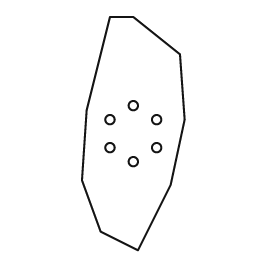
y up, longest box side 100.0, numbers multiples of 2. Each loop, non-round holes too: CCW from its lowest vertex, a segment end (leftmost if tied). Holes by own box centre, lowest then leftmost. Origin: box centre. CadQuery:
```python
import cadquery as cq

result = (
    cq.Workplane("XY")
    .moveTo(2.0, -50.0)
    .lineTo(16.0, -22.0)
    .lineTo(22.0, 6.0)
    .lineTo(20.0, 34.0)
    .lineTo(0.0, 50.0)
    .lineTo(-10.0, 50.0)
    .lineTo(-20.0, 10.0)
    .lineTo(-22.0, -20.0)
    .lineTo(-14.0, -42.0)
    .close()
    .moveTo(0.0, -12.0)
    .circle(2.0)
    .moveTo(-10.0, -6.0)
    .circle(2.0)
    .moveTo(10.0, -6.0)
    .circle(2.0)
    .moveTo(-10.0, 6.0)
    .circle(2.0)
    .moveTo(10.0, 6.0)
    .circle(2.0)
    .moveTo(0.0, 12.0)
    .circle(2.0)
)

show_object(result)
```